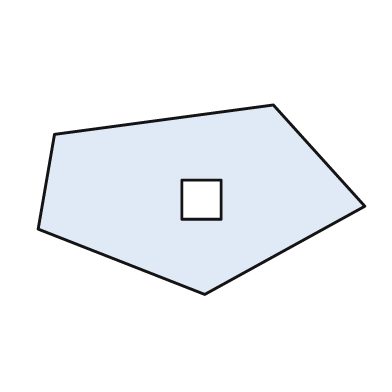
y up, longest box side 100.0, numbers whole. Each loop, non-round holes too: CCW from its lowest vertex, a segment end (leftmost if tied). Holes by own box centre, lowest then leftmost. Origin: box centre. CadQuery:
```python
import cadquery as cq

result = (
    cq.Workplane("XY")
    .moveTo(1.0, -29.0)
    .lineTo(50.0, -2.0)
    .lineTo(22.0, 29.0)
    .lineTo(-45.0, 20.0)
    .lineTo(-50.0, -9.0)
    .close()
    .moveTo(-6.0, -6.0)
    .lineTo(6.0, -6.0)
    .lineTo(6.0, 6.0)
    .lineTo(-6.0, 6.0)
    .close()
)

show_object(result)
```